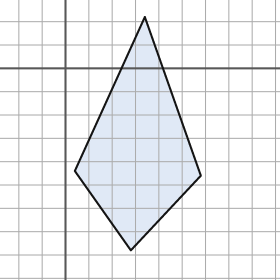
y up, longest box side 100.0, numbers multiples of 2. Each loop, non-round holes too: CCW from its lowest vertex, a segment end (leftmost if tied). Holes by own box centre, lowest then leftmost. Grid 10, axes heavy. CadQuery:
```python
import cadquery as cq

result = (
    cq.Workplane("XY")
    .moveTo(28.0, -78.0)
    .lineTo(58.0, -46.0)
    .lineTo(34.0, 22.0)
    .lineTo(4.0, -44.0)
    .close()
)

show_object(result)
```